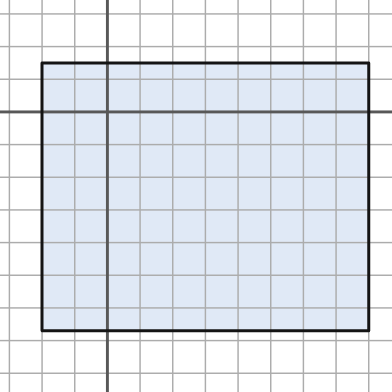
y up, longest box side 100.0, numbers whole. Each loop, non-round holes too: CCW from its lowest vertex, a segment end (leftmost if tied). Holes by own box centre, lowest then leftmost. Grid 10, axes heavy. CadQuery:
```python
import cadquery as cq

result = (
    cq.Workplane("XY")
    .moveTo(-20.0, -67.0)
    .lineTo(80.0, -67.0)
    .lineTo(80.0, 15.0)
    .lineTo(-20.0, 15.0)
    .close()
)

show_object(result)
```